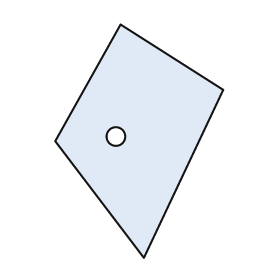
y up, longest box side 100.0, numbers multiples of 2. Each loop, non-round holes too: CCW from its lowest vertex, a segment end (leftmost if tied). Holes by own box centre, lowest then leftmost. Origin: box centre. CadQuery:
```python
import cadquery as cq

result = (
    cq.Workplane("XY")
    .moveTo(2.0, -50.0)
    .lineTo(36.0, 22.0)
    .lineTo(-8.0, 50.0)
    .lineTo(-36.0, 0.0)
    .close()
    .moveTo(-10.0, 2.0)
    .circle(4.0)
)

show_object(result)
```